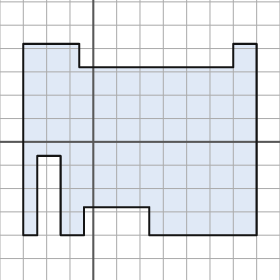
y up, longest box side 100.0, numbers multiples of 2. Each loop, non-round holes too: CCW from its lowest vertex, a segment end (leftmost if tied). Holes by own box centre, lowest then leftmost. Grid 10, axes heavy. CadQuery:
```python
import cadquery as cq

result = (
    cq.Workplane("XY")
    .moveTo(-30.0, -40.0)
    .lineTo(-24.0, -40.0)
    .lineTo(-24.0, -6.0)
    .lineTo(-14.0, -6.0)
    .lineTo(-14.0, -40.0)
    .lineTo(-4.0, -40.0)
    .lineTo(-4.0, -28.0)
    .lineTo(24.0, -28.0)
    .lineTo(24.0, -40.0)
    .lineTo(70.0, -40.0)
    .lineTo(70.0, 42.0)
    .lineTo(60.0, 42.0)
    .lineTo(60.0, 32.0)
    .lineTo(-6.0, 32.0)
    .lineTo(-6.0, 42.0)
    .lineTo(-30.0, 42.0)
    .close()
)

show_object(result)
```